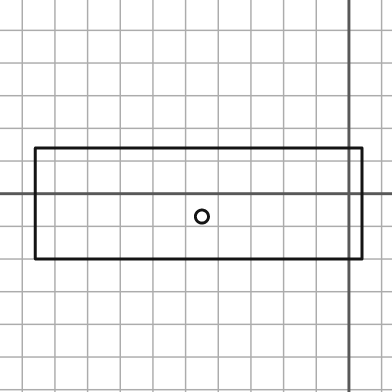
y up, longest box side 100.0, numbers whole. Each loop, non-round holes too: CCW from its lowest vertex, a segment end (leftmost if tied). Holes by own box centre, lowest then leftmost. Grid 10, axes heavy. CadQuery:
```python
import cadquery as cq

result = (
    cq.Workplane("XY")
    .moveTo(-96.0, -20.0)
    .lineTo(4.0, -20.0)
    .lineTo(4.0, 14.0)
    .lineTo(-96.0, 14.0)
    .close()
    .moveTo(-45.0, -7.0)
    .circle(2.0)
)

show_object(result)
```